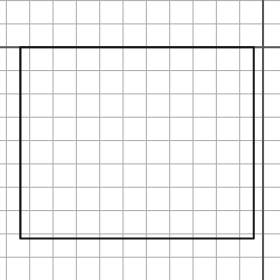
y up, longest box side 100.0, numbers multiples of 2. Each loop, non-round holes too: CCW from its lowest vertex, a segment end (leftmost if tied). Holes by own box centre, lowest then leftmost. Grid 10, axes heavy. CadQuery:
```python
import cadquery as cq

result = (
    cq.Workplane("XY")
    .moveTo(-104.0, -82.0)
    .lineTo(-4.0, -82.0)
    .lineTo(-4.0, 0.0)
    .lineTo(-104.0, 0.0)
    .close()
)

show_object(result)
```